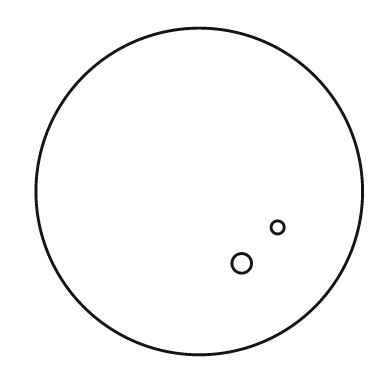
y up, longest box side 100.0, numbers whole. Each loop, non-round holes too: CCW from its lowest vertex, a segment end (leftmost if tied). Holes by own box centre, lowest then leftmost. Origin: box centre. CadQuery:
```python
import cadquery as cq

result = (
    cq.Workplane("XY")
    .moveTo(0.0, 0.0)
    .circle(50.0)
    .moveTo(13.0, -22.0)
    .circle(3.0)
    .moveTo(24.0, -11.0)
    .circle(2.0)
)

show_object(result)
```